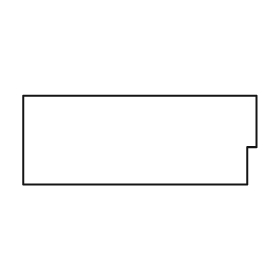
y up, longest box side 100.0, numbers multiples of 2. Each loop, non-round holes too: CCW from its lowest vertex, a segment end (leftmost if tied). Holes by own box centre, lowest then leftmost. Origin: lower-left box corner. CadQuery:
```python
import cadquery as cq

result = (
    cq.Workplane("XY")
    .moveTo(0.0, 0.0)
    .lineTo(96.0, 0.0)
    .lineTo(96.0, 16.0)
    .lineTo(100.0, 16.0)
    .lineTo(100.0, 38.0)
    .lineTo(0.0, 38.0)
    .close()
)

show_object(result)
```